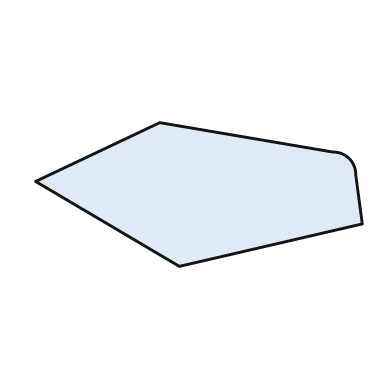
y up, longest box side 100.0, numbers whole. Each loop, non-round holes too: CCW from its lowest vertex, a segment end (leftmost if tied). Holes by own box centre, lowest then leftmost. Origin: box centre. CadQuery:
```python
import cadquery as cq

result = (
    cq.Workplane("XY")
    .moveTo(-6.0, -22.0)
    .lineTo(50.0, -9.0)
    .lineTo(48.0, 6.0)
    .threePointArc((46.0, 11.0), (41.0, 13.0))
    .lineTo(-12.0, 22.0)
    .lineTo(-50.0, 4.0)
    .close()
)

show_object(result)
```